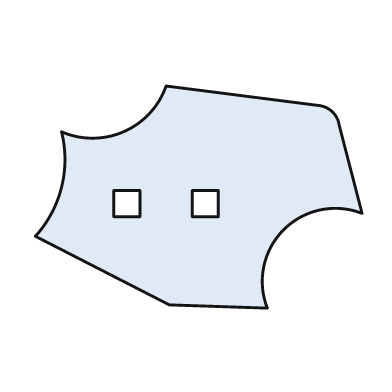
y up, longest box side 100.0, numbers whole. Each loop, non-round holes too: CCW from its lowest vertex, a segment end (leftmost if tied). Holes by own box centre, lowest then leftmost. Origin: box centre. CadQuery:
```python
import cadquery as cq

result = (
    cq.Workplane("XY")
    .moveTo(21.0, -34.0)
    .threePointArc((26.0, -10.0), (50.0, -5.0))
    .lineTo(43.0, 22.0)
    .threePointArc((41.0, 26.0), (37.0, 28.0))
    .lineTo(-10.0, 34.0)
    .threePointArc((-23.0, 20.0), (-42.0, 20.0))
    .threePointArc((-42.0, 3.0), (-50.0, -12.0))
    .lineTo(-9.0, -33.0)
    .close()
    .moveTo(-26.0, -6.0)
    .lineTo(-18.0, -6.0)
    .lineTo(-18.0, 2.0)
    .lineTo(-26.0, 2.0)
    .close()
    .moveTo(-2.0, -6.0)
    .lineTo(6.0, -6.0)
    .lineTo(6.0, 2.0)
    .lineTo(-2.0, 2.0)
    .close()
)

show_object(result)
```